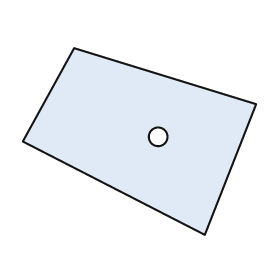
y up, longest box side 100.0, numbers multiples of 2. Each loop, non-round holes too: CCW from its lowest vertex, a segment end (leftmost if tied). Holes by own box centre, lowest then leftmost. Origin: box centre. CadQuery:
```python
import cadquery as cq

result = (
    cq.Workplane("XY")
    .moveTo(28.0, -40.0)
    .lineTo(50.0, 16.0)
    .lineTo(-28.0, 40.0)
    .lineTo(-50.0, 0.0)
    .close()
    .moveTo(8.0, 2.0)
    .circle(4.0)
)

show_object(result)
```